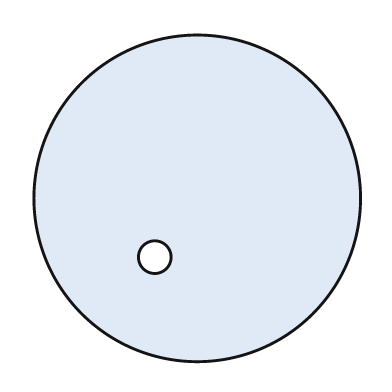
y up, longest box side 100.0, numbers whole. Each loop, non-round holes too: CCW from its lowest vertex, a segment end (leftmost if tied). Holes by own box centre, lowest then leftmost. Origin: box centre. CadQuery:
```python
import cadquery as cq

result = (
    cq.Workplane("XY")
    .moveTo(0.0, 0.0)
    .circle(50.0)
    .moveTo(-13.0, -18.0)
    .circle(5.0)
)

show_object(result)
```